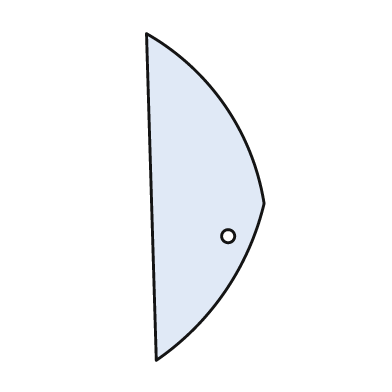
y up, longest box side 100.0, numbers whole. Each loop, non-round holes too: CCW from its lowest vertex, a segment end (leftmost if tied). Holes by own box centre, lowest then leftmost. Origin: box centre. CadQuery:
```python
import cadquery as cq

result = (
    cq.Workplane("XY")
    .moveTo(-15.0, -50.0)
    .threePointArc((6.0, -29.0), (18.0, -2.0))
    .threePointArc((6.0, 28.0), (-18.0, 50.0))
    .close()
    .moveTo(7.0, -12.0)
    .circle(2.0)
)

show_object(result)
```